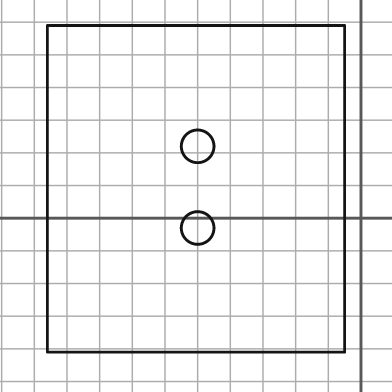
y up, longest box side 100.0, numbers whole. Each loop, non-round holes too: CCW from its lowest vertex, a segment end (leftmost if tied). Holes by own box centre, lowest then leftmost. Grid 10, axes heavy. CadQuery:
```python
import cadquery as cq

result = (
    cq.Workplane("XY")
    .moveTo(-96.0, -41.0)
    .lineTo(-5.0, -41.0)
    .lineTo(-5.0, 59.0)
    .lineTo(-96.0, 59.0)
    .close()
    .moveTo(-50.0, -3.0)
    .circle(5.0)
    .moveTo(-50.0, 22.0)
    .circle(5.0)
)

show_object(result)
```